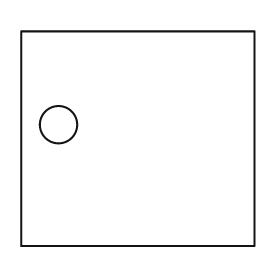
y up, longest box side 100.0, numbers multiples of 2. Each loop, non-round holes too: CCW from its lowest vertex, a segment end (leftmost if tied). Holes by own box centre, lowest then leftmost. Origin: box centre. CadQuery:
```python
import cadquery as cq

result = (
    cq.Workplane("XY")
    .moveTo(-50.0, -46.0)
    .lineTo(50.0, -46.0)
    .lineTo(50.0, 46.0)
    .lineTo(-50.0, 46.0)
    .close()
    .moveTo(-34.0, 6.0)
    .circle(8.0)
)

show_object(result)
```